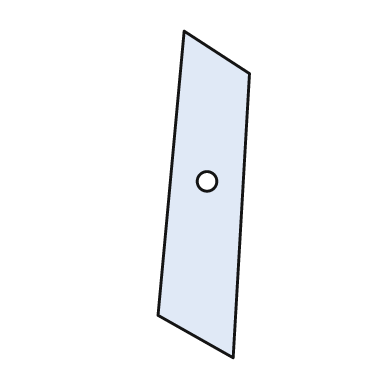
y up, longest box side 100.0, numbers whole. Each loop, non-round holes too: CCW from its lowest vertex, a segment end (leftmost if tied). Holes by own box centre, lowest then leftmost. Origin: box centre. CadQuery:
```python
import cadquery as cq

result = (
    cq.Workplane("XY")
    .moveTo(9.0, -50.0)
    .lineTo(14.0, 37.0)
    .lineTo(-6.0, 50.0)
    .lineTo(-14.0, -37.0)
    .close()
    .moveTo(1.0, 4.0)
    .circle(3.0)
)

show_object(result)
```